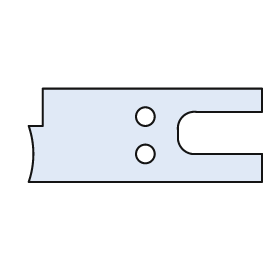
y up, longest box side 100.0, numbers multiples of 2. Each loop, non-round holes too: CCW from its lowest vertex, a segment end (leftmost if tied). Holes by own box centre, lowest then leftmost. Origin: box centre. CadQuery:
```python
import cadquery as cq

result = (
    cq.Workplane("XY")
    .moveTo(-50.0, -20.0)
    .lineTo(50.0, -20.0)
    .lineTo(50.0, -8.0)
    .lineTo(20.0, -8.0)
    .threePointArc((16.0, -6.0), (14.0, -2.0))
    .lineTo(14.0, 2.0)
    .threePointArc((16.0, 8.0), (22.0, 10.0))
    .lineTo(50.0, 10.0)
    .lineTo(50.0, 20.0)
    .lineTo(-44.0, 20.0)
    .lineTo(-44.0, 4.0)
    .lineTo(-50.0, 4.0)
    .threePointArc((-48.0, -8.0), (-50.0, -20.0))
    .close()
    .moveTo(0.0, -8.0)
    .circle(4.0)
    .moveTo(0.0, 8.0)
    .circle(4.0)
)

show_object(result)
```